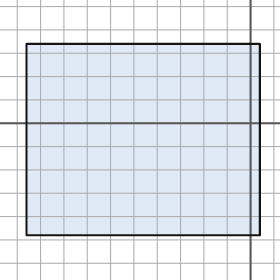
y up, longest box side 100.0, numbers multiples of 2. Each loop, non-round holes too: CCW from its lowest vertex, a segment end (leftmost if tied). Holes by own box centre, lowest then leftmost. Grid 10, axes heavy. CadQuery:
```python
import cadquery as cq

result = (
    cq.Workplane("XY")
    .moveTo(-96.0, -48.0)
    .lineTo(4.0, -48.0)
    .lineTo(4.0, 34.0)
    .lineTo(-96.0, 34.0)
    .close()
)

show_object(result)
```